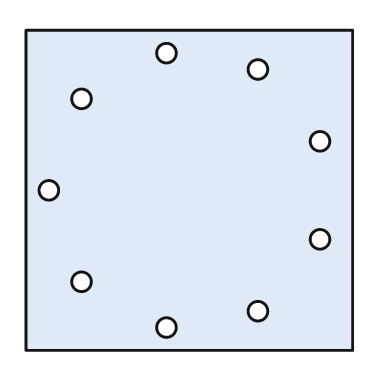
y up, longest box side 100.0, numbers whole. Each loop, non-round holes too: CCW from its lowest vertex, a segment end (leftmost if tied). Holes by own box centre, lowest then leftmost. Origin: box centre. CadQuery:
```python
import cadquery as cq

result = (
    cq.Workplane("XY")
    .moveTo(-50.0, -49.0)
    .lineTo(50.0, -49.0)
    .lineTo(50.0, 49.0)
    .lineTo(-50.0, 49.0)
    .close()
    .moveTo(-7.0, -42.0)
    .circle(3.0)
    .moveTo(21.0, -37.0)
    .circle(3.0)
    .moveTo(-33.0, -28.0)
    .circle(3.0)
    .moveTo(40.0, -15.0)
    .circle(3.0)
    .moveTo(-43.0, 0.0)
    .circle(3.0)
    .moveTo(40.0, 15.0)
    .circle(3.0)
    .moveTo(-33.0, 28.0)
    .circle(3.0)
    .moveTo(21.0, 37.0)
    .circle(3.0)
    .moveTo(-7.0, 42.0)
    .circle(3.0)
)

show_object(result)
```